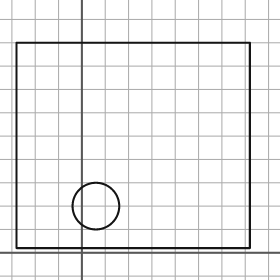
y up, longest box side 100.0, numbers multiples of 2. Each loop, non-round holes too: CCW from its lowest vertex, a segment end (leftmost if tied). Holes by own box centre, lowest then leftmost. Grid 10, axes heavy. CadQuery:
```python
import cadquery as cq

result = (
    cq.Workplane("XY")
    .moveTo(-28.0, 2.0)
    .lineTo(72.0, 2.0)
    .lineTo(72.0, 90.0)
    .lineTo(-28.0, 90.0)
    .close()
    .moveTo(6.0, 20.0)
    .circle(10.0)
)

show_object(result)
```